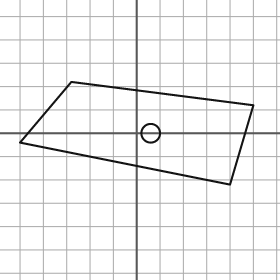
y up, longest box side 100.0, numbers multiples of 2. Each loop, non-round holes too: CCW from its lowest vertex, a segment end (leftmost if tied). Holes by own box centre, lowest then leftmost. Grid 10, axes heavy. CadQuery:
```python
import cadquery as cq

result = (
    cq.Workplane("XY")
    .moveTo(40.0, -22.0)
    .lineTo(50.0, 12.0)
    .lineTo(-28.0, 22.0)
    .lineTo(-50.0, -4.0)
    .close()
    .moveTo(6.0, 0.0)
    .circle(4.0)
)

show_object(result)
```